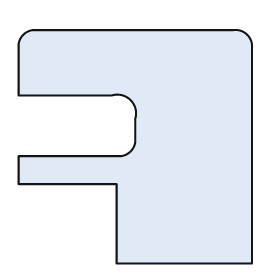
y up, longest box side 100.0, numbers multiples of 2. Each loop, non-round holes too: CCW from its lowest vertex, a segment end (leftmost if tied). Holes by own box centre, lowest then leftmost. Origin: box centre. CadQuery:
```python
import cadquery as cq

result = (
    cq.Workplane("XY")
    .moveTo(-8.0, -50.0)
    .lineTo(50.0, -50.0)
    .lineTo(50.0, 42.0)
    .threePointArc((48.0, 48.0), (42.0, 50.0))
    .lineTo(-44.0, 50.0)
    .threePointArc((-48.0, 48.0), (-50.0, 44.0))
    .lineTo(-50.0, 22.0)
    .lineTo(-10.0, 22.0)
    .threePointArc((-2.0, 20.0), (0.0, 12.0))
    .lineTo(0.0, 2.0)
    .threePointArc((-2.0, -2.0), (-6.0, -4.0))
    .lineTo(-50.0, -4.0)
    .lineTo(-50.0, -16.0)
    .lineTo(-8.0, -16.0)
    .close()
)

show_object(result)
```